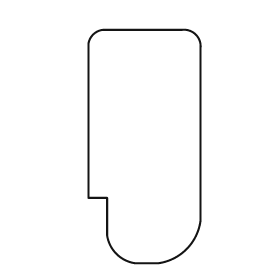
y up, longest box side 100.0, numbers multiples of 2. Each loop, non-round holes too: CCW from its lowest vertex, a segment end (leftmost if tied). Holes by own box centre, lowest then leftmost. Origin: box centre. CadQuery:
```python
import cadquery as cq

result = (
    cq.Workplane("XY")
    .moveTo(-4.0, -50.0)
    .lineTo(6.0, -50.0)
    .threePointArc((18.0, -44.0), (24.0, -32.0))
    .lineTo(24.0, 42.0)
    .threePointArc((22.0, 48.0), (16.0, 50.0))
    .lineTo(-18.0, 50.0)
    .threePointArc((-22.0, 48.0), (-24.0, 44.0))
    .lineTo(-24.0, -22.0)
    .lineTo(-16.0, -22.0)
    .lineTo(-16.0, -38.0)
    .threePointArc((-12.0, -46.0), (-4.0, -50.0))
    .close()
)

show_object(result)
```